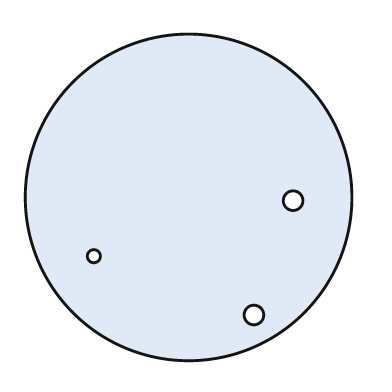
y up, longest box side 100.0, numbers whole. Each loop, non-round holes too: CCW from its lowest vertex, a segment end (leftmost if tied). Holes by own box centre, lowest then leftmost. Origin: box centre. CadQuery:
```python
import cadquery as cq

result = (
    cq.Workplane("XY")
    .moveTo(0.0, 0.0)
    .circle(50.0)
    .moveTo(20.0, -36.0)
    .circle(3.0)
    .moveTo(-29.0, -18.0)
    .circle(2.0)
    .moveTo(32.0, -1.0)
    .circle(3.0)
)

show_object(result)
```